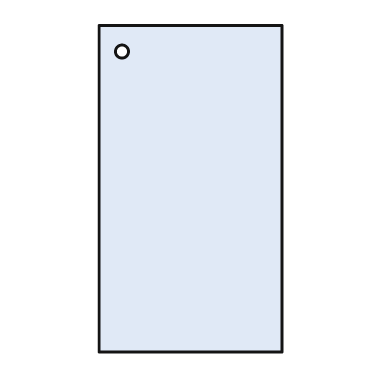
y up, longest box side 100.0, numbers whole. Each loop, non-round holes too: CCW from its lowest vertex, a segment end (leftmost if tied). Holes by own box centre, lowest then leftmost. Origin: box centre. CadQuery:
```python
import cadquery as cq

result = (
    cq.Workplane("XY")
    .moveTo(-28.0, -50.0)
    .lineTo(28.0, -50.0)
    .lineTo(28.0, 50.0)
    .lineTo(-28.0, 50.0)
    .close()
    .moveTo(-21.0, 42.0)
    .circle(2.0)
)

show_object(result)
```